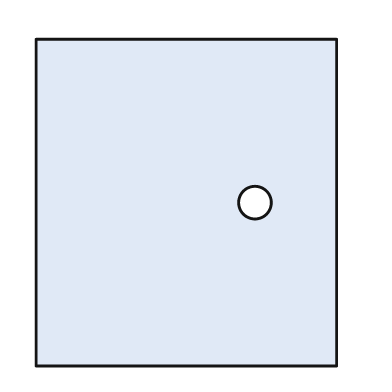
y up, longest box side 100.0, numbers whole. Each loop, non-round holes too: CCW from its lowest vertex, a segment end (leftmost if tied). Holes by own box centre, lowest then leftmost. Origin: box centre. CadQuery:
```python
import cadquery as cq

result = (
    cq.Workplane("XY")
    .moveTo(-46.0, -50.0)
    .lineTo(46.0, -50.0)
    .lineTo(46.0, 50.0)
    .lineTo(-46.0, 50.0)
    .close()
    .moveTo(21.0, 0.0)
    .circle(5.0)
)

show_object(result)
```